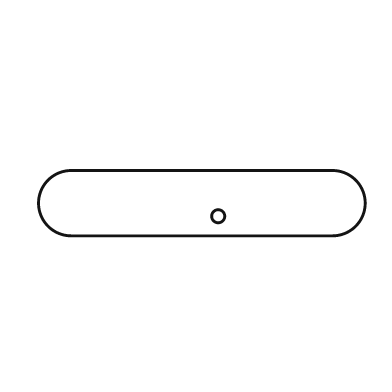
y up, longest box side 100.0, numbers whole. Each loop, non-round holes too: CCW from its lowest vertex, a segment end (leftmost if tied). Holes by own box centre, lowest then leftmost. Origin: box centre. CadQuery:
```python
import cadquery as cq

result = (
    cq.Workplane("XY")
    .moveTo(-40.0, -10.0)
    .lineTo(40.0, -10.0)
    .threePointArc((50.0, 0.0), (40.0, 10.0))
    .lineTo(-40.0, 10.0)
    .threePointArc((-50.0, 0.0), (-40.0, -10.0))
    .close()
    .moveTo(5.0, -4.0)
    .circle(2.0)
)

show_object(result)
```